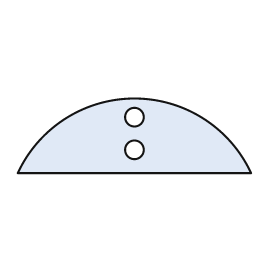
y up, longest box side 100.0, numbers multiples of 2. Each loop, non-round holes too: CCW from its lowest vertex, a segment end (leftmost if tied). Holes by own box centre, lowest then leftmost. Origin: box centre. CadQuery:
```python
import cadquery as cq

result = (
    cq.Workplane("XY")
    .moveTo(-50.0, -16.0)
    .lineTo(50.0, -16.0)
    .threePointArc((0.0, 16.0), (-50.0, -16.0))
    .close()
    .moveTo(0.0, -6.0)
    .circle(4.0)
    .moveTo(0.0, 8.0)
    .circle(4.0)
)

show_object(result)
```